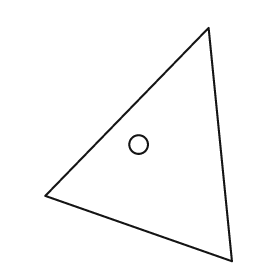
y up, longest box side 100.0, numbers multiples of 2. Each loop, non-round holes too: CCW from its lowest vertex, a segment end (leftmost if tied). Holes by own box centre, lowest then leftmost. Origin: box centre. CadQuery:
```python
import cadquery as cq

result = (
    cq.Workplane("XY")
    .moveTo(40.0, -50.0)
    .lineTo(30.0, 50.0)
    .lineTo(-40.0, -22.0)
    .close()
    .moveTo(0.0, 0.0)
    .circle(4.0)
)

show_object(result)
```